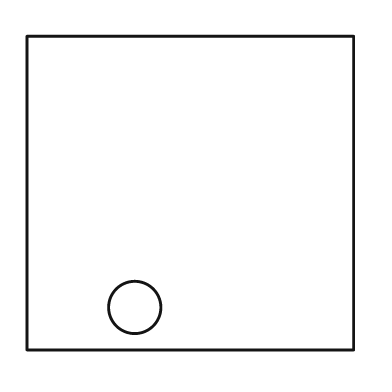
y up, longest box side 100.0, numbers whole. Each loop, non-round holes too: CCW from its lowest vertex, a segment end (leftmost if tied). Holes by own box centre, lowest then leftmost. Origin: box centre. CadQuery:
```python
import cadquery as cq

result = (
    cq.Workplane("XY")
    .moveTo(-50.0, -48.0)
    .lineTo(50.0, -48.0)
    .lineTo(50.0, 48.0)
    .lineTo(-50.0, 48.0)
    .close()
    .moveTo(-17.0, -35.0)
    .circle(8.0)
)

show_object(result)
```